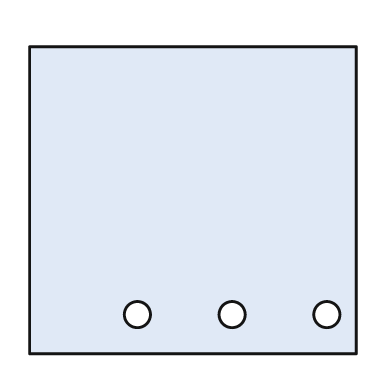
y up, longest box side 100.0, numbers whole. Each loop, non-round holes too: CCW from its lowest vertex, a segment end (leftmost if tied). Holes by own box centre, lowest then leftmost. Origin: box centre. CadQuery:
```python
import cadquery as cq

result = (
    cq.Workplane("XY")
    .moveTo(-50.0, -47.0)
    .lineTo(50.0, -47.0)
    .lineTo(50.0, 47.0)
    .lineTo(-50.0, 47.0)
    .close()
    .moveTo(-17.0, -35.0)
    .circle(4.0)
    .moveTo(12.0, -35.0)
    .circle(4.0)
    .moveTo(41.0, -35.0)
    .circle(4.0)
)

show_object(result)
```